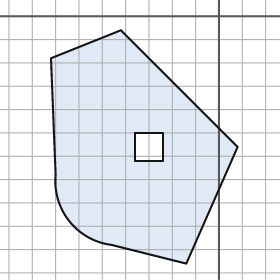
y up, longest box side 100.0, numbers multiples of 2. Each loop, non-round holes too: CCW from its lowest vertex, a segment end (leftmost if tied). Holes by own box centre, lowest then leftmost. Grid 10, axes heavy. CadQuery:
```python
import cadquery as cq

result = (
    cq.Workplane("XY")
    .moveTo(-14.0, -106.0)
    .lineTo(8.0, -56.0)
    .lineTo(-42.0, -6.0)
    .lineTo(-72.0, -18.0)
    .lineTo(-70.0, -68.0)
    .threePointArc((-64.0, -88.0), (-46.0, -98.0))
    .close()
    .moveTo(-36.0, -62.0)
    .lineTo(-24.0, -62.0)
    .lineTo(-24.0, -50.0)
    .lineTo(-36.0, -50.0)
    .close()
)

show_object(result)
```